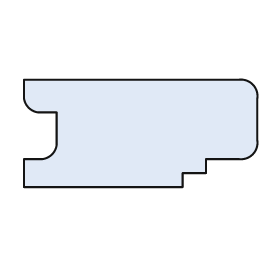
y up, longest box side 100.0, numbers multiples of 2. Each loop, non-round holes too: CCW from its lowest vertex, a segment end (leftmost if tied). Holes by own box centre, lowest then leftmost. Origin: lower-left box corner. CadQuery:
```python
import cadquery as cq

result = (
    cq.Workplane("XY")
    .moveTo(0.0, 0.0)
    .lineTo(68.0, 0.0)
    .lineTo(68.0, 6.0)
    .lineTo(78.0, 6.0)
    .lineTo(78.0, 12.0)
    .lineTo(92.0, 12.0)
    .threePointArc((98.0, 14.0), (100.0, 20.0))
    .lineTo(100.0, 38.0)
    .threePointArc((98.0, 44.0), (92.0, 46.0))
    .lineTo(0.0, 46.0)
    .lineTo(0.0, 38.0)
    .threePointArc((2.0, 34.0), (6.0, 32.0))
    .lineTo(14.0, 32.0)
    .lineTo(14.0, 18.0)
    .threePointArc((12.0, 14.0), (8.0, 12.0))
    .lineTo(0.0, 12.0)
    .close()
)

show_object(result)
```